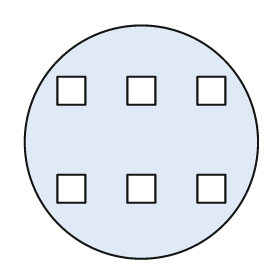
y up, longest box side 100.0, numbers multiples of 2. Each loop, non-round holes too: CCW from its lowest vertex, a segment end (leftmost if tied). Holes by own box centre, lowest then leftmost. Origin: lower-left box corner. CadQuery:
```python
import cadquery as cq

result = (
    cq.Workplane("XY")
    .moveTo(50.0, 50.0)
    .circle(50.0)
    .moveTo(14.0, 24.0)
    .lineTo(26.0, 24.0)
    .lineTo(26.0, 36.0)
    .lineTo(14.0, 36.0)
    .close()
    .moveTo(44.0, 24.0)
    .lineTo(56.0, 24.0)
    .lineTo(56.0, 36.0)
    .lineTo(44.0, 36.0)
    .close()
    .moveTo(74.0, 24.0)
    .lineTo(86.0, 24.0)
    .lineTo(86.0, 36.0)
    .lineTo(74.0, 36.0)
    .close()
    .moveTo(14.0, 66.0)
    .lineTo(26.0, 66.0)
    .lineTo(26.0, 78.0)
    .lineTo(14.0, 78.0)
    .close()
    .moveTo(44.0, 66.0)
    .lineTo(56.0, 66.0)
    .lineTo(56.0, 78.0)
    .lineTo(44.0, 78.0)
    .close()
    .moveTo(74.0, 66.0)
    .lineTo(86.0, 66.0)
    .lineTo(86.0, 78.0)
    .lineTo(74.0, 78.0)
    .close()
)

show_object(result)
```